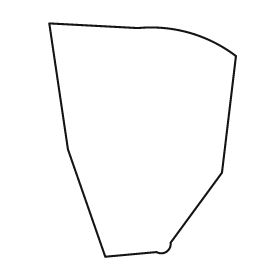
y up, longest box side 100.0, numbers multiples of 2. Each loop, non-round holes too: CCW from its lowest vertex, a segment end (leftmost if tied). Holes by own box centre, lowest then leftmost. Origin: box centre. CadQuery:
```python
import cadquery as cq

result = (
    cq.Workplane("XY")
    .moveTo(-16.0, -50.0)
    .lineTo(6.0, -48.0)
    .threePointArc((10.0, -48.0), (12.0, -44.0))
    .lineTo(34.0, -14.0)
    .lineTo(40.0, 36.0)
    .threePointArc((20.0, 46.0), (-2.0, 48.0))
    .lineTo(-40.0, 50.0)
    .lineTo(-32.0, -4.0)
    .close()
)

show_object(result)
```